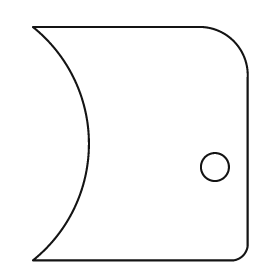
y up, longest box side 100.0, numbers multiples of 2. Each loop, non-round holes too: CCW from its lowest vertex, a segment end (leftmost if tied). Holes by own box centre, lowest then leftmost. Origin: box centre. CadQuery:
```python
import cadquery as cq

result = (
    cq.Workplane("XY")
    .moveTo(-46.0, -50.0)
    .lineTo(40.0, -50.0)
    .threePointArc((44.0, -48.0), (46.0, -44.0))
    .lineTo(46.0, 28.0)
    .threePointArc((40.0, 44.0), (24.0, 50.0))
    .lineTo(-46.0, 50.0)
    .threePointArc((-22.0, 0.0), (-46.0, -50.0))
    .close()
    .moveTo(32.0, -10.0)
    .circle(6.0)
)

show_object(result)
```